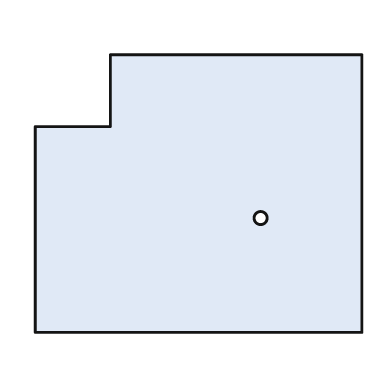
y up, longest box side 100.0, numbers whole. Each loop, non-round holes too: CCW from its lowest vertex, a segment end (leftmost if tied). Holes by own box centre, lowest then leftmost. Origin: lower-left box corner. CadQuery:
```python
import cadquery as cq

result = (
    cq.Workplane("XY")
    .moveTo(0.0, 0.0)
    .lineTo(100.0, 0.0)
    .lineTo(100.0, 85.0)
    .lineTo(23.0, 85.0)
    .lineTo(23.0, 63.0)
    .lineTo(0.0, 63.0)
    .close()
    .moveTo(69.0, 35.0)
    .circle(2.0)
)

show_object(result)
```